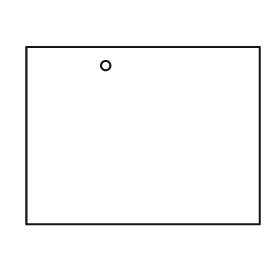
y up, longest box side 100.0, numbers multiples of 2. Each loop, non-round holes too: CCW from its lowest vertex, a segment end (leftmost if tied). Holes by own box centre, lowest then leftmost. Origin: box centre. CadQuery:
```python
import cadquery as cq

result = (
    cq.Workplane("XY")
    .moveTo(-50.0, -38.0)
    .lineTo(50.0, -38.0)
    .lineTo(50.0, 38.0)
    .lineTo(-50.0, 38.0)
    .close()
    .moveTo(-16.0, 30.0)
    .circle(2.0)
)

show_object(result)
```